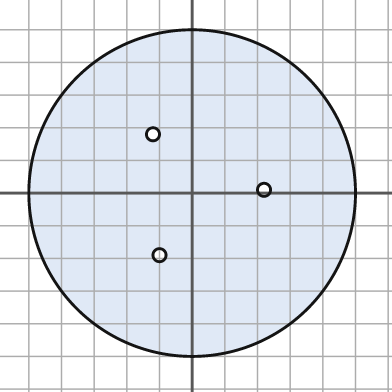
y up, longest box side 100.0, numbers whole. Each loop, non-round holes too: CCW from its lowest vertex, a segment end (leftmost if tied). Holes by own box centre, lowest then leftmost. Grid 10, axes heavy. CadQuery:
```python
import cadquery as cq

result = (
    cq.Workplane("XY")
    .moveTo(0.0, 0.0)
    .circle(50.0)
    .moveTo(-10.0, -19.0)
    .circle(2.0)
    .moveTo(22.0, 1.0)
    .circle(2.0)
    .moveTo(-12.0, 18.0)
    .circle(2.0)
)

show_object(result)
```